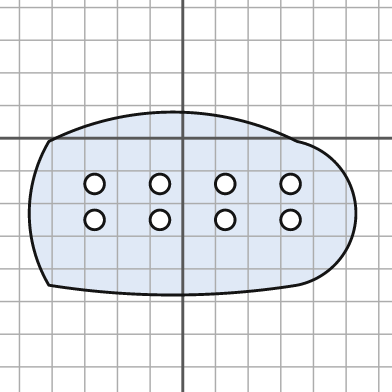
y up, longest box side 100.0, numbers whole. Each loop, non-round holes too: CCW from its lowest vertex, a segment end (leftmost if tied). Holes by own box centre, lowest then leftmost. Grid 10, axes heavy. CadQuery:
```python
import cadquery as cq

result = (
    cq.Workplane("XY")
    .moveTo(-41.0, -45.0)
    .threePointArc((-3.0, -48.0), (35.0, -45.0))
    .threePointArc((53.0, -23.0), (35.0, -1.0))
    .threePointArc((-3.0, 8.0), (-41.0, -1.0))
    .threePointArc((-47.0, -23.0), (-41.0, -45.0))
    .close()
    .moveTo(-27.0, -25.0)
    .circle(3.0)
    .moveTo(-7.0, -25.0)
    .circle(3.0)
    .moveTo(13.0, -25.0)
    .circle(3.0)
    .moveTo(33.0, -25.0)
    .circle(3.0)
    .moveTo(-27.0, -14.0)
    .circle(3.0)
    .moveTo(-7.0, -14.0)
    .circle(3.0)
    .moveTo(13.0, -14.0)
    .circle(3.0)
    .moveTo(33.0, -14.0)
    .circle(3.0)
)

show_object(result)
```